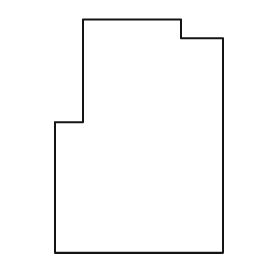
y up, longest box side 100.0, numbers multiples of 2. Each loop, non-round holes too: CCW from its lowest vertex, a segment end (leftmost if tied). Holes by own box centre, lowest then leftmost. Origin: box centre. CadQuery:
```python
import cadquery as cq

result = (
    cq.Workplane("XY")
    .moveTo(-36.0, -50.0)
    .lineTo(36.0, -50.0)
    .lineTo(36.0, 42.0)
    .lineTo(18.0, 42.0)
    .lineTo(18.0, 50.0)
    .lineTo(-24.0, 50.0)
    .lineTo(-24.0, 6.0)
    .lineTo(-36.0, 6.0)
    .close()
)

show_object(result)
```